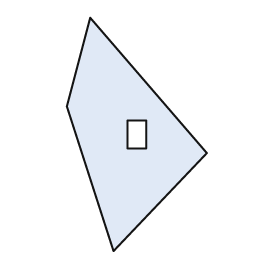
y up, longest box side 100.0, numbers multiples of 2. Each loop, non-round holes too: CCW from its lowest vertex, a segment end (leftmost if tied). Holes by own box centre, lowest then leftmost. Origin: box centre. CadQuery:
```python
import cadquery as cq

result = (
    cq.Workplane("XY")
    .moveTo(-10.0, -50.0)
    .lineTo(30.0, -8.0)
    .lineTo(-20.0, 50.0)
    .lineTo(-30.0, 12.0)
    .close()
    .moveTo(-4.0, -6.0)
    .lineTo(4.0, -6.0)
    .lineTo(4.0, 6.0)
    .lineTo(-4.0, 6.0)
    .close()
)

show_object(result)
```